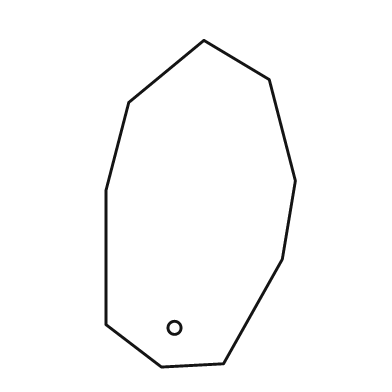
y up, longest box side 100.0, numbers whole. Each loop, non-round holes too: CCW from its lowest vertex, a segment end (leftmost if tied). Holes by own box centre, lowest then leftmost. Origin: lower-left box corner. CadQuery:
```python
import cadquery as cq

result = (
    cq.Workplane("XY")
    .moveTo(17.0, 0.0)
    .lineTo(36.0, 1.0)
    .lineTo(54.0, 33.0)
    .lineTo(58.0, 57.0)
    .lineTo(50.0, 88.0)
    .lineTo(30.0, 100.0)
    .lineTo(7.0, 81.0)
    .lineTo(0.0, 54.0)
    .lineTo(0.0, 13.0)
    .close()
    .moveTo(21.0, 12.0)
    .circle(2.0)
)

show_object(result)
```